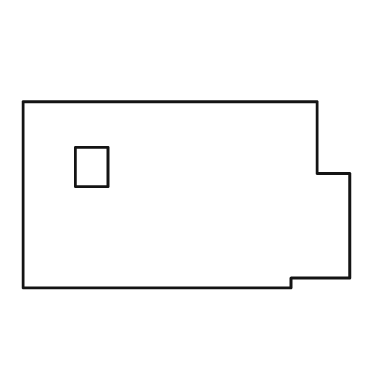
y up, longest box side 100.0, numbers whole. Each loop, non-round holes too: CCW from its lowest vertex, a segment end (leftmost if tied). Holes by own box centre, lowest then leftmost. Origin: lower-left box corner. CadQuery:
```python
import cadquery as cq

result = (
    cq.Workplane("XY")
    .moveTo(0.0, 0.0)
    .lineTo(82.0, 0.0)
    .lineTo(82.0, 3.0)
    .lineTo(100.0, 3.0)
    .lineTo(100.0, 35.0)
    .lineTo(90.0, 35.0)
    .lineTo(90.0, 57.0)
    .lineTo(0.0, 57.0)
    .close()
    .moveTo(16.0, 31.0)
    .lineTo(26.0, 31.0)
    .lineTo(26.0, 43.0)
    .lineTo(16.0, 43.0)
    .close()
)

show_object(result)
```